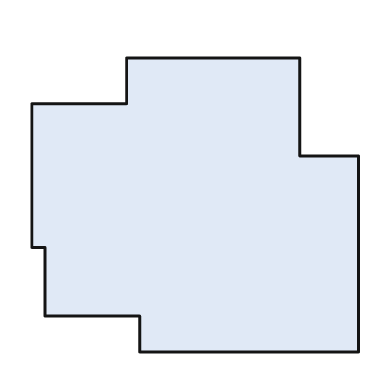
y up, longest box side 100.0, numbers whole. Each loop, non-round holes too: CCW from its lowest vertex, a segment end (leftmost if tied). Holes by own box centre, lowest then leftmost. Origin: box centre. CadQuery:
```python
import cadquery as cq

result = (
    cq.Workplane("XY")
    .moveTo(-17.0, -45.0)
    .lineTo(50.0, -45.0)
    .lineTo(50.0, 15.0)
    .lineTo(32.0, 15.0)
    .lineTo(32.0, 45.0)
    .lineTo(-21.0, 45.0)
    .lineTo(-21.0, 31.0)
    .lineTo(-50.0, 31.0)
    .lineTo(-50.0, -13.0)
    .lineTo(-46.0, -13.0)
    .lineTo(-46.0, -34.0)
    .lineTo(-17.0, -34.0)
    .close()
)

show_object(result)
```